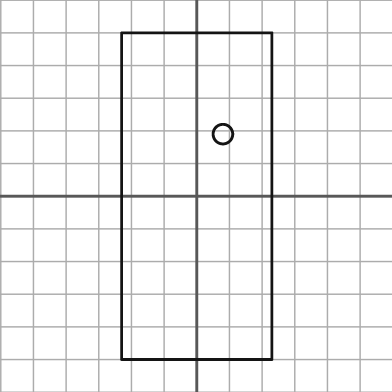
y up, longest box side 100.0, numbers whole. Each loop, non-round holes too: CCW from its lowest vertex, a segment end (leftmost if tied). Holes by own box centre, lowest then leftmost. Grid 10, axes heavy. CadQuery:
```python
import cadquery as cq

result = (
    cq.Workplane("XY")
    .moveTo(-23.0, -50.0)
    .lineTo(23.0, -50.0)
    .lineTo(23.0, 50.0)
    .lineTo(-23.0, 50.0)
    .close()
    .moveTo(8.0, 19.0)
    .circle(3.0)
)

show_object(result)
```